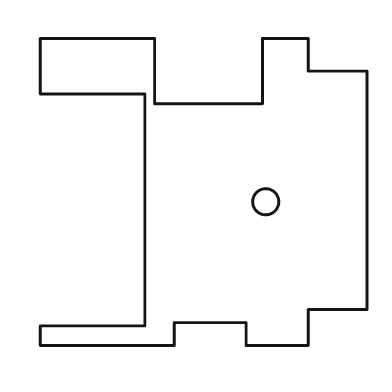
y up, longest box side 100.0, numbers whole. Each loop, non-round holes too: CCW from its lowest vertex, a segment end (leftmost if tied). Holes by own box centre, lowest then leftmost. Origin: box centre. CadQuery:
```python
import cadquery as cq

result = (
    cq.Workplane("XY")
    .moveTo(-50.0, -47.0)
    .lineTo(-9.0, -47.0)
    .lineTo(-9.0, -40.0)
    .lineTo(13.0, -40.0)
    .lineTo(13.0, -47.0)
    .lineTo(32.0, -47.0)
    .lineTo(32.0, -36.0)
    .lineTo(50.0, -36.0)
    .lineTo(50.0, 37.0)
    .lineTo(32.0, 37.0)
    .lineTo(32.0, 47.0)
    .lineTo(18.0, 47.0)
    .lineTo(18.0, 27.0)
    .lineTo(-15.0, 27.0)
    .lineTo(-15.0, 47.0)
    .lineTo(-50.0, 47.0)
    .lineTo(-50.0, 30.0)
    .lineTo(-18.0, 30.0)
    .lineTo(-18.0, -41.0)
    .lineTo(-50.0, -41.0)
    .close()
    .moveTo(19.0, -3.0)
    .circle(4.0)
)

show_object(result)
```